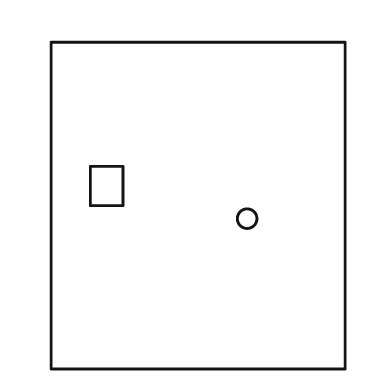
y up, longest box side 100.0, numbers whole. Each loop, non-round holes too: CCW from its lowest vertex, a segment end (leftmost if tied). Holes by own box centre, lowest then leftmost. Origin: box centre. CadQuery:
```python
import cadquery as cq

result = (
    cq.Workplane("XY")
    .moveTo(-45.0, -50.0)
    .lineTo(45.0, -50.0)
    .lineTo(45.0, 50.0)
    .lineTo(-45.0, 50.0)
    .close()
    .moveTo(15.0, -4.0)
    .circle(3.0)
    .moveTo(-33.0, 0.0)
    .lineTo(-23.0, 0.0)
    .lineTo(-23.0, 12.0)
    .lineTo(-33.0, 12.0)
    .close()
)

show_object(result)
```